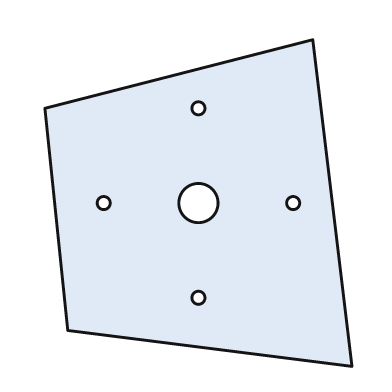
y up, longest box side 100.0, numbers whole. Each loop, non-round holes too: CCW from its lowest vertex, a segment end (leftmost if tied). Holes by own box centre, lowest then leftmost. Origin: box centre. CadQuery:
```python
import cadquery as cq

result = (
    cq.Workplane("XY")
    .moveTo(47.0, -50.0)
    .lineTo(35.0, 50.0)
    .lineTo(-47.0, 29.0)
    .lineTo(-40.0, -39.0)
    .close()
    .moveTo(0.0, -29.0)
    .circle(2.0)
    .moveTo(-29.0, 0.0)
    .circle(2.0)
    .moveTo(0.0, 0.0)
    .circle(6.0)
    .moveTo(29.0, 0.0)
    .circle(2.0)
    .moveTo(0.0, 29.0)
    .circle(2.0)
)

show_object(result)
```